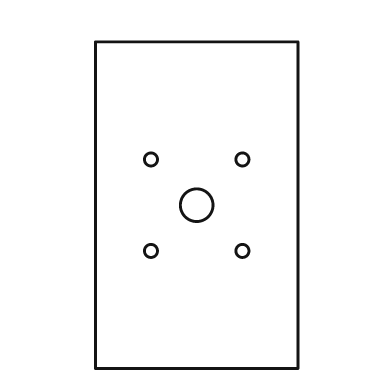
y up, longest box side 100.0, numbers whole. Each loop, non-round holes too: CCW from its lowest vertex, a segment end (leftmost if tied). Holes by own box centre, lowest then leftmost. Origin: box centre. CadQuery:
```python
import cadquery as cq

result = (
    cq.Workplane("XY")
    .moveTo(-31.0, -50.0)
    .lineTo(31.0, -50.0)
    .lineTo(31.0, 50.0)
    .lineTo(-31.0, 50.0)
    .close()
    .moveTo(-14.0, -14.0)
    .circle(2.0)
    .moveTo(14.0, -14.0)
    .circle(2.0)
    .moveTo(0.0, 0.0)
    .circle(5.0)
    .moveTo(-14.0, 14.0)
    .circle(2.0)
    .moveTo(14.0, 14.0)
    .circle(2.0)
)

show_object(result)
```